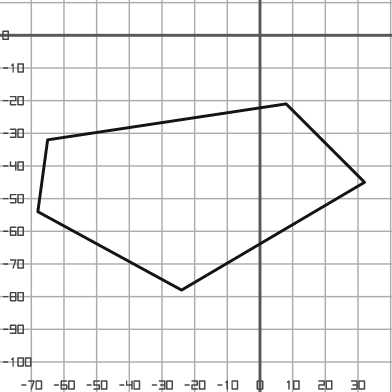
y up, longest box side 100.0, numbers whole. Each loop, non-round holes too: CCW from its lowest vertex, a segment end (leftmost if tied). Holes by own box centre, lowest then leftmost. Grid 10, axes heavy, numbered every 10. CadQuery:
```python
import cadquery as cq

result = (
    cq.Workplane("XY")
    .moveTo(-24.0, -78.0)
    .lineTo(32.0, -45.0)
    .lineTo(8.0, -21.0)
    .lineTo(-65.0, -32.0)
    .lineTo(-68.0, -54.0)
    .close()
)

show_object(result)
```